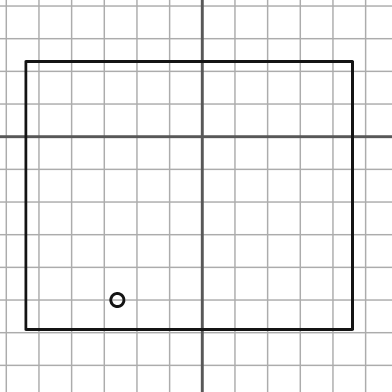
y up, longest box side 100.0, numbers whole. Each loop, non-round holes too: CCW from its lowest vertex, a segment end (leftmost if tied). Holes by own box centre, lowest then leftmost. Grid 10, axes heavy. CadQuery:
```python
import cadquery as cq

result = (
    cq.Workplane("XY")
    .moveTo(-54.0, -59.0)
    .lineTo(46.0, -59.0)
    .lineTo(46.0, 23.0)
    .lineTo(-54.0, 23.0)
    .close()
    .moveTo(-26.0, -50.0)
    .circle(2.0)
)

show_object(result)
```